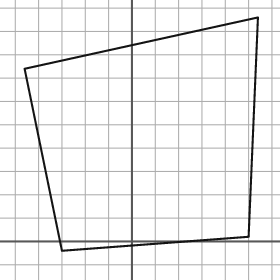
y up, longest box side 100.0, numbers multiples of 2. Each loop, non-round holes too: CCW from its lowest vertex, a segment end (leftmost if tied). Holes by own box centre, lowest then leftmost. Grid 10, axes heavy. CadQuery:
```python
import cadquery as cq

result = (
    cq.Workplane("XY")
    .moveTo(-30.0, -4.0)
    .lineTo(50.0, 2.0)
    .lineTo(54.0, 96.0)
    .lineTo(-46.0, 74.0)
    .close()
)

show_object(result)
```